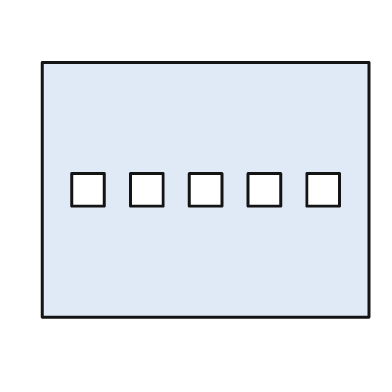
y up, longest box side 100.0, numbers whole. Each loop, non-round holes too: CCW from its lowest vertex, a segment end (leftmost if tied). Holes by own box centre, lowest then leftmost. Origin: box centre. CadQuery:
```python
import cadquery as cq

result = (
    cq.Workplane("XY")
    .moveTo(-50.0, -39.0)
    .lineTo(50.0, -39.0)
    .lineTo(50.0, 39.0)
    .lineTo(-50.0, 39.0)
    .close()
    .moveTo(-41.0, -5.0)
    .lineTo(-31.0, -5.0)
    .lineTo(-31.0, 5.0)
    .lineTo(-41.0, 5.0)
    .close()
    .moveTo(-23.0, -5.0)
    .lineTo(-13.0, -5.0)
    .lineTo(-13.0, 5.0)
    .lineTo(-23.0, 5.0)
    .close()
    .moveTo(-5.0, -5.0)
    .lineTo(5.0, -5.0)
    .lineTo(5.0, 5.0)
    .lineTo(-5.0, 5.0)
    .close()
    .moveTo(13.0, -5.0)
    .lineTo(23.0, -5.0)
    .lineTo(23.0, 5.0)
    .lineTo(13.0, 5.0)
    .close()
    .moveTo(31.0, -5.0)
    .lineTo(41.0, -5.0)
    .lineTo(41.0, 5.0)
    .lineTo(31.0, 5.0)
    .close()
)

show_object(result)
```